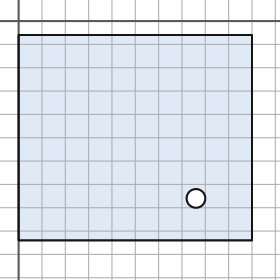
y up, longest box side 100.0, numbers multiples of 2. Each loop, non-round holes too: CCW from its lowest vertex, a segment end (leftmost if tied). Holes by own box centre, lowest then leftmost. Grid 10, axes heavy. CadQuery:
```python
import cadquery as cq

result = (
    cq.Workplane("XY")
    .moveTo(0.0, -94.0)
    .lineTo(100.0, -94.0)
    .lineTo(100.0, -6.0)
    .lineTo(0.0, -6.0)
    .close()
    .moveTo(76.0, -76.0)
    .circle(4.0)
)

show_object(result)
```